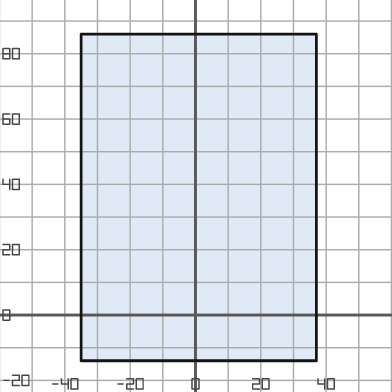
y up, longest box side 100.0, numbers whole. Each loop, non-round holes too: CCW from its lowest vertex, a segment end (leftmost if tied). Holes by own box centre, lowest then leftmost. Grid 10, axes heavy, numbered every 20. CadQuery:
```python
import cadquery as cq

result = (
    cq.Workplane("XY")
    .moveTo(-35.0, -14.0)
    .lineTo(37.0, -14.0)
    .lineTo(37.0, 86.0)
    .lineTo(-35.0, 86.0)
    .close()
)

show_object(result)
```